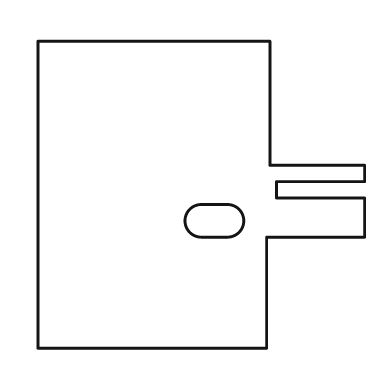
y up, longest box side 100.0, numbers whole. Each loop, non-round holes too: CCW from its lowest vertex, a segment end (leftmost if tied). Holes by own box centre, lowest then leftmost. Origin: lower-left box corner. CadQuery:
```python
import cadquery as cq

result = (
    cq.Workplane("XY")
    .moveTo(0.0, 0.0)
    .lineTo(70.0, 0.0)
    .lineTo(70.0, 34.0)
    .lineTo(100.0, 34.0)
    .lineTo(100.0, 46.0)
    .lineTo(73.0, 46.0)
    .lineTo(73.0, 51.0)
    .lineTo(100.0, 51.0)
    .lineTo(100.0, 56.0)
    .lineTo(71.0, 56.0)
    .lineTo(71.0, 94.0)
    .lineTo(0.0, 94.0)
    .close()
    .moveTo(50.0, 34.0)
    .lineTo(58.0, 34.0)
    .threePointArc((63.0, 39.0), (58.0, 44.0))
    .lineTo(50.0, 44.0)
    .threePointArc((45.0, 39.0), (50.0, 34.0))
    .close()
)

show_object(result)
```